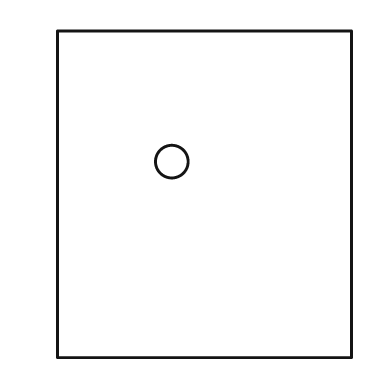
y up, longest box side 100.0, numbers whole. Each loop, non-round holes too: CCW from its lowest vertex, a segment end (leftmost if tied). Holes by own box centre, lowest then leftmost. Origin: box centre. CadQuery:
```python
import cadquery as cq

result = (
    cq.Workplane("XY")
    .moveTo(-45.0, -50.0)
    .lineTo(45.0, -50.0)
    .lineTo(45.0, 50.0)
    .lineTo(-45.0, 50.0)
    .close()
    .moveTo(-10.0, 10.0)
    .circle(5.0)
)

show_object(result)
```